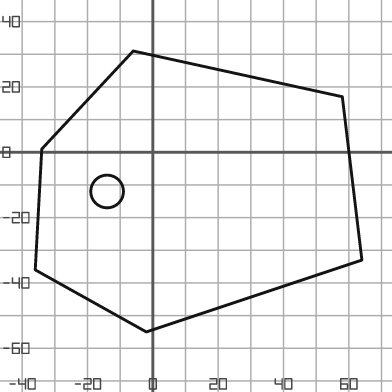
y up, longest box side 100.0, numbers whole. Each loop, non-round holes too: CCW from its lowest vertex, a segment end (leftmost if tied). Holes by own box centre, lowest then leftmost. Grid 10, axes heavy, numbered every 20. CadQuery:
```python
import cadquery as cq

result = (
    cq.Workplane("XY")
    .moveTo(-2.0, -55.0)
    .lineTo(64.0, -33.0)
    .lineTo(58.0, 17.0)
    .lineTo(-6.0, 31.0)
    .lineTo(-34.0, 1.0)
    .lineTo(-36.0, -36.0)
    .close()
    .moveTo(-14.0, -12.0)
    .circle(5.0)
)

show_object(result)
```